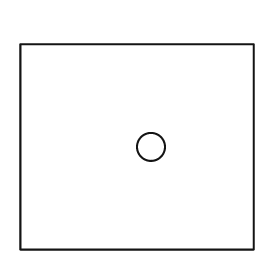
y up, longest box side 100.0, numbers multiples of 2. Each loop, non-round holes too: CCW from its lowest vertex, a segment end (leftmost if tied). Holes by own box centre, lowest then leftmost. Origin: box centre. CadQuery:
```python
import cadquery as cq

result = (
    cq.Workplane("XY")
    .moveTo(-50.0, -44.0)
    .lineTo(50.0, -44.0)
    .lineTo(50.0, 44.0)
    .lineTo(-50.0, 44.0)
    .close()
    .moveTo(6.0, 0.0)
    .circle(6.0)
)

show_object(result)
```